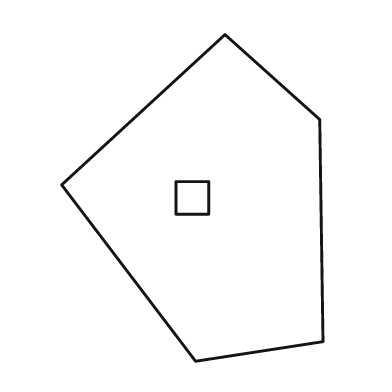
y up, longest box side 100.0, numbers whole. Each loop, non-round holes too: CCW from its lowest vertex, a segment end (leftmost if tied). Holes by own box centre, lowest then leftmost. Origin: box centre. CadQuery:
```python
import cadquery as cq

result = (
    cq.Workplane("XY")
    .moveTo(1.0, -50.0)
    .lineTo(40.0, -44.0)
    .lineTo(39.0, 24.0)
    .lineTo(10.0, 50.0)
    .lineTo(-40.0, 4.0)
    .close()
    .moveTo(-5.0, -5.0)
    .lineTo(5.0, -5.0)
    .lineTo(5.0, 5.0)
    .lineTo(-5.0, 5.0)
    .close()
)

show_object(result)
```